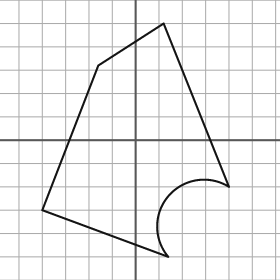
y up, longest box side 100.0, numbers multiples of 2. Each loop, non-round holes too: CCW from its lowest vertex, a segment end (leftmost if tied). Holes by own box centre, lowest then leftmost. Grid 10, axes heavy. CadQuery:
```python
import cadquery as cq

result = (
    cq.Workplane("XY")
    .moveTo(14.0, -50.0)
    .threePointArc((14.0, -24.0), (40.0, -20.0))
    .lineTo(12.0, 50.0)
    .lineTo(-16.0, 32.0)
    .lineTo(-40.0, -30.0)
    .close()
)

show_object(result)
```